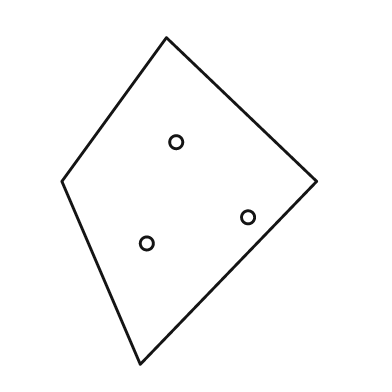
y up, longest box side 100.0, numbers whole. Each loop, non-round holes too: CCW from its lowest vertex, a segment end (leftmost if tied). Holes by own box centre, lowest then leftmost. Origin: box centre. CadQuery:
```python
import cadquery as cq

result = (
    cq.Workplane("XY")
    .moveTo(-15.0, -50.0)
    .lineTo(39.0, 6.0)
    .lineTo(-7.0, 50.0)
    .lineTo(-39.0, 6.0)
    .close()
    .moveTo(-13.0, -13.0)
    .circle(2.0)
    .moveTo(18.0, -5.0)
    .circle(2.0)
    .moveTo(-4.0, 18.0)
    .circle(2.0)
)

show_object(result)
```